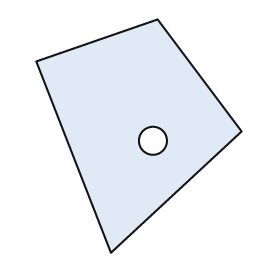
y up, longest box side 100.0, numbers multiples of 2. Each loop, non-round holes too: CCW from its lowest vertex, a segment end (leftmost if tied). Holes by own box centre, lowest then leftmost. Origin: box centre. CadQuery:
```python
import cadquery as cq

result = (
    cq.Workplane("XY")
    .moveTo(-12.0, -50.0)
    .lineTo(44.0, 2.0)
    .lineTo(8.0, 50.0)
    .lineTo(-44.0, 32.0)
    .close()
    .moveTo(6.0, -2.0)
    .circle(6.0)
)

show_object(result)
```